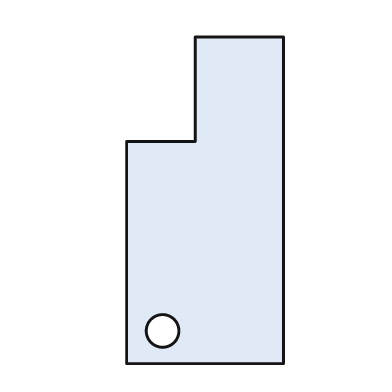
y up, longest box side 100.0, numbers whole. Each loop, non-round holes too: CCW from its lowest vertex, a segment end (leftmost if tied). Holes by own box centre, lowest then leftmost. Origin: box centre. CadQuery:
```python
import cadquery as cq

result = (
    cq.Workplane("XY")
    .moveTo(-24.0, -50.0)
    .lineTo(24.0, -50.0)
    .lineTo(24.0, 50.0)
    .lineTo(-3.0, 50.0)
    .lineTo(-3.0, 18.0)
    .lineTo(-24.0, 18.0)
    .close()
    .moveTo(-13.0, -40.0)
    .circle(5.0)
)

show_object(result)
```